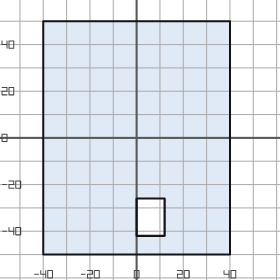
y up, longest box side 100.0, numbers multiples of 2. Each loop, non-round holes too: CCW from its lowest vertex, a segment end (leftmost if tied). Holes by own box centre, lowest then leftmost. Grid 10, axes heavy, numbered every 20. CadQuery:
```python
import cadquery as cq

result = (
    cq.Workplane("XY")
    .moveTo(-40.0, -50.0)
    .lineTo(40.0, -50.0)
    .lineTo(40.0, 50.0)
    .lineTo(-40.0, 50.0)
    .close()
    .moveTo(0.0, -42.0)
    .lineTo(12.0, -42.0)
    .lineTo(12.0, -26.0)
    .lineTo(0.0, -26.0)
    .close()
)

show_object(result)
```